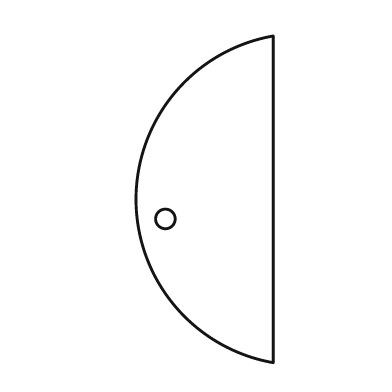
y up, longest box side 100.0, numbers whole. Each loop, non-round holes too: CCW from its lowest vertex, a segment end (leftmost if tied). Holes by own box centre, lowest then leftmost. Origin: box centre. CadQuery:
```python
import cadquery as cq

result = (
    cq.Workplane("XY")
    .moveTo(21.0, -50.0)
    .lineTo(21.0, 50.0)
    .threePointArc((-21.0, 0.0), (21.0, -50.0))
    .close()
    .moveTo(-12.0, -6.0)
    .circle(3.0)
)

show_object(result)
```